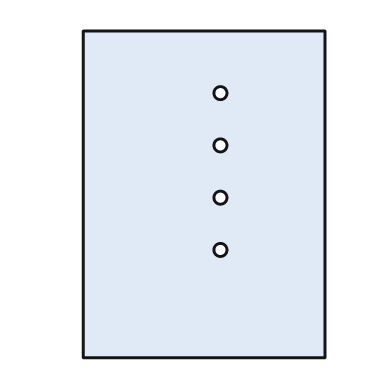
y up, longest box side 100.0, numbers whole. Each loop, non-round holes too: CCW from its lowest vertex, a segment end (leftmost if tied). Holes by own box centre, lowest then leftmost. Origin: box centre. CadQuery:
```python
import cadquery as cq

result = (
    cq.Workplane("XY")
    .moveTo(-37.0, -50.0)
    .lineTo(37.0, -50.0)
    .lineTo(37.0, 50.0)
    .lineTo(-37.0, 50.0)
    .close()
    .moveTo(5.0, -17.0)
    .circle(2.0)
    .moveTo(5.0, -1.0)
    .circle(2.0)
    .moveTo(5.0, 15.0)
    .circle(2.0)
    .moveTo(5.0, 31.0)
    .circle(2.0)
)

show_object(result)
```